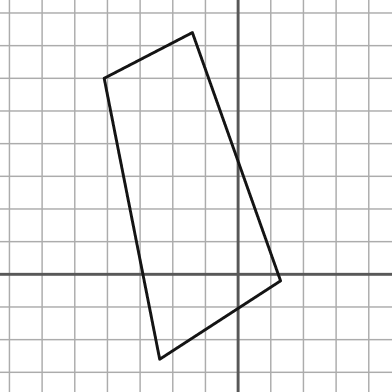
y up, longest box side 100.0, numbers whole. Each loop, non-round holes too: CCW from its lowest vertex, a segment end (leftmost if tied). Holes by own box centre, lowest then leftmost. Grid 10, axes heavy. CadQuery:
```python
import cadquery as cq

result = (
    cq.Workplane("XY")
    .moveTo(-24.0, -26.0)
    .lineTo(13.0, -2.0)
    .lineTo(-14.0, 74.0)
    .lineTo(-41.0, 60.0)
    .close()
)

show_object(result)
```